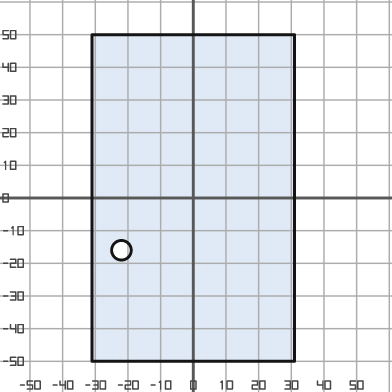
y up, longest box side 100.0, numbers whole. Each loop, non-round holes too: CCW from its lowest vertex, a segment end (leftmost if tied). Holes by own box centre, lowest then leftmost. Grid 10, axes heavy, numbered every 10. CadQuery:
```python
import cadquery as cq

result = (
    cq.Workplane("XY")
    .moveTo(-31.0, -50.0)
    .lineTo(31.0, -50.0)
    .lineTo(31.0, 50.0)
    .lineTo(-31.0, 50.0)
    .close()
    .moveTo(-22.0, -16.0)
    .circle(3.0)
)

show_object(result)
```